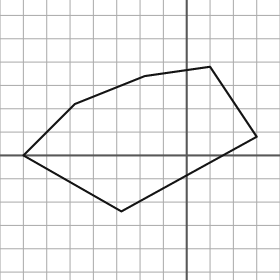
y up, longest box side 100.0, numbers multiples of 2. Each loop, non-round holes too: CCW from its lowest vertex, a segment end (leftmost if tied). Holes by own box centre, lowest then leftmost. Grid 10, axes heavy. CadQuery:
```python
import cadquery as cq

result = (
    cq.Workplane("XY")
    .moveTo(-28.0, -24.0)
    .lineTo(30.0, 8.0)
    .lineTo(10.0, 38.0)
    .lineTo(-18.0, 34.0)
    .lineTo(-48.0, 22.0)
    .lineTo(-70.0, 0.0)
    .close()
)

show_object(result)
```